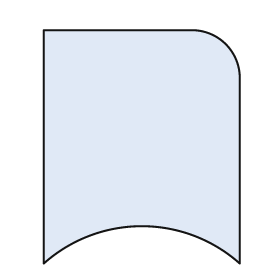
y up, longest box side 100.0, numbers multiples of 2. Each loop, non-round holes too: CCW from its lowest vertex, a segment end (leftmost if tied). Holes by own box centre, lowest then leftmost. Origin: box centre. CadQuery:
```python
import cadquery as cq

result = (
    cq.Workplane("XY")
    .moveTo(-42.0, -50.0)
    .threePointArc((0.0, -34.0), (42.0, -50.0))
    .lineTo(42.0, 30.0)
    .threePointArc((36.0, 44.0), (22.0, 50.0))
    .lineTo(-42.0, 50.0)
    .close()
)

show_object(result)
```